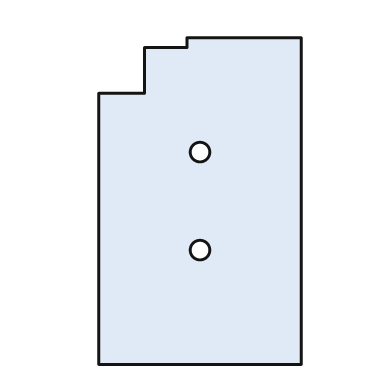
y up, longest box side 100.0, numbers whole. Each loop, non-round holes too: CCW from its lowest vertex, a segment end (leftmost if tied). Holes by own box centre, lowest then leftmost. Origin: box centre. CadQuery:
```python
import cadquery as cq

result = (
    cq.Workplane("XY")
    .moveTo(-31.0, -50.0)
    .lineTo(31.0, -50.0)
    .lineTo(31.0, 50.0)
    .lineTo(-4.0, 50.0)
    .lineTo(-4.0, 47.0)
    .lineTo(-17.0, 47.0)
    .lineTo(-17.0, 33.0)
    .lineTo(-31.0, 33.0)
    .close()
    .moveTo(0.0, -15.0)
    .circle(3.0)
    .moveTo(0.0, 15.0)
    .circle(3.0)
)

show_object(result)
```